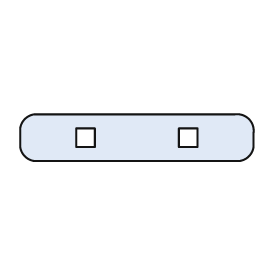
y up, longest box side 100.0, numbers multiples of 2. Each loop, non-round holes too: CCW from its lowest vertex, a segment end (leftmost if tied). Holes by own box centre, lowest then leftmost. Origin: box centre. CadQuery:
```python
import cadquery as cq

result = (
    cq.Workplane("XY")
    .moveTo(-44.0, -10.0)
    .lineTo(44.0, -10.0)
    .threePointArc((48.0, -8.0), (50.0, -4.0))
    .lineTo(50.0, 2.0)
    .threePointArc((48.0, 8.0), (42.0, 10.0))
    .lineTo(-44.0, 10.0)
    .threePointArc((-48.0, 8.0), (-50.0, 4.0))
    .lineTo(-50.0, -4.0)
    .threePointArc((-48.0, -8.0), (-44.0, -10.0))
    .close()
    .moveTo(-26.0, -4.0)
    .lineTo(-18.0, -4.0)
    .lineTo(-18.0, 4.0)
    .lineTo(-26.0, 4.0)
    .close()
    .moveTo(18.0, -4.0)
    .lineTo(26.0, -4.0)
    .lineTo(26.0, 4.0)
    .lineTo(18.0, 4.0)
    .close()
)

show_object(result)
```